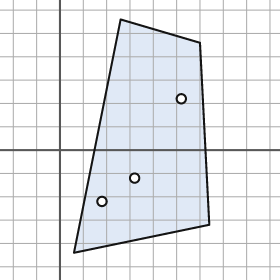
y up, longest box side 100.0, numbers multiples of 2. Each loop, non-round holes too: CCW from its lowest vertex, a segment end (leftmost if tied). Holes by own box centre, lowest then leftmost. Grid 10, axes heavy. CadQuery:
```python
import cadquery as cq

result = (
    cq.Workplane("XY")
    .moveTo(6.0, -44.0)
    .lineTo(64.0, -32.0)
    .lineTo(60.0, 46.0)
    .lineTo(26.0, 56.0)
    .close()
    .moveTo(18.0, -22.0)
    .circle(2.0)
    .moveTo(32.0, -12.0)
    .circle(2.0)
    .moveTo(52.0, 22.0)
    .circle(2.0)
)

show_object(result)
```